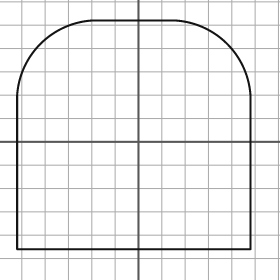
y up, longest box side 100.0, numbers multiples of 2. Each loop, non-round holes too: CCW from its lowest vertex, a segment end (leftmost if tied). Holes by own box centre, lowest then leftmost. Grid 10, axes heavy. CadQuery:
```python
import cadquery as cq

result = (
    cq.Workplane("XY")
    .moveTo(-52.0, -46.0)
    .lineTo(48.0, -46.0)
    .lineTo(48.0, 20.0)
    .threePointArc((38.0, 42.0), (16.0, 52.0))
    .lineTo(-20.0, 52.0)
    .threePointArc((-42.0, 42.0), (-52.0, 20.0))
    .close()
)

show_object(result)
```